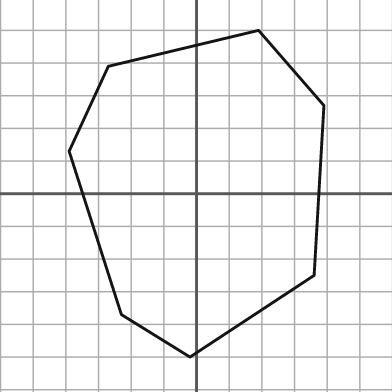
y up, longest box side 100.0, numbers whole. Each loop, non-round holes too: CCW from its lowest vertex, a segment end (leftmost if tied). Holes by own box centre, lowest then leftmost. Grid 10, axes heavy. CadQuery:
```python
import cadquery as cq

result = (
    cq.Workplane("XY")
    .moveTo(-2.0, -50.0)
    .lineTo(36.0, -25.0)
    .lineTo(39.0, 27.0)
    .lineTo(19.0, 50.0)
    .lineTo(-27.0, 39.0)
    .lineTo(-39.0, 13.0)
    .lineTo(-23.0, -37.0)
    .close()
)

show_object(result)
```